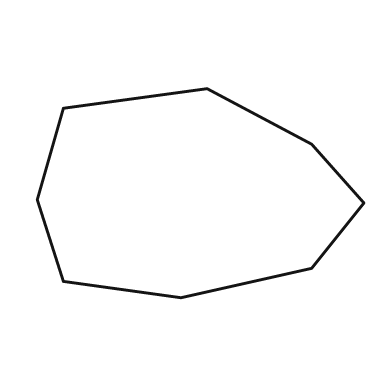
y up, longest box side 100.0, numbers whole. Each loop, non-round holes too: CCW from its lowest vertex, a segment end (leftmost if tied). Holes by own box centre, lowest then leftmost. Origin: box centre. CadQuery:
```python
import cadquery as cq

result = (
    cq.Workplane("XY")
    .moveTo(-6.0, -32.0)
    .lineTo(34.0, -23.0)
    .lineTo(50.0, -3.0)
    .lineTo(34.0, 15.0)
    .lineTo(2.0, 32.0)
    .lineTo(-42.0, 26.0)
    .lineTo(-50.0, -2.0)
    .lineTo(-42.0, -27.0)
    .close()
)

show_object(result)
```